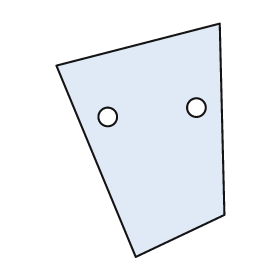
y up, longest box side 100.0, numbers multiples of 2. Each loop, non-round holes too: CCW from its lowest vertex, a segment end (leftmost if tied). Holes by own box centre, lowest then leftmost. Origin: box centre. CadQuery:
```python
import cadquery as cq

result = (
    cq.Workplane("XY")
    .moveTo(-2.0, -50.0)
    .lineTo(36.0, -32.0)
    .lineTo(34.0, 50.0)
    .lineTo(-36.0, 32.0)
    .close()
    .moveTo(-14.0, 10.0)
    .circle(4.0)
    .moveTo(24.0, 14.0)
    .circle(4.0)
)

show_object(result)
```